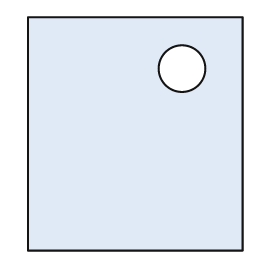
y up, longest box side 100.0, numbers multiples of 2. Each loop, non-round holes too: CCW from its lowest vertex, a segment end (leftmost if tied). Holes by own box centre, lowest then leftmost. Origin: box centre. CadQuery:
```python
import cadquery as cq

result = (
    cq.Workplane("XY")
    .moveTo(-46.0, -50.0)
    .lineTo(46.0, -50.0)
    .lineTo(46.0, 50.0)
    .lineTo(-46.0, 50.0)
    .close()
    .moveTo(20.0, 28.0)
    .circle(10.0)
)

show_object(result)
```